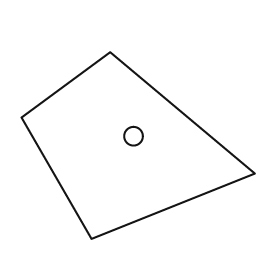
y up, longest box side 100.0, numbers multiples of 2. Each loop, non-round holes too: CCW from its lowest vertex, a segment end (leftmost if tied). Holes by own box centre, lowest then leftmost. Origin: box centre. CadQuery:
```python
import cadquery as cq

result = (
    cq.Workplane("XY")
    .moveTo(-20.0, -40.0)
    .lineTo(50.0, -12.0)
    .lineTo(-12.0, 40.0)
    .lineTo(-50.0, 12.0)
    .close()
    .moveTo(-2.0, 4.0)
    .circle(4.0)
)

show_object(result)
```